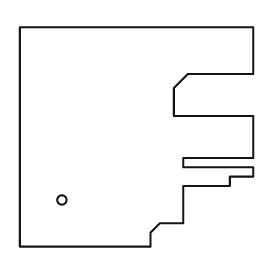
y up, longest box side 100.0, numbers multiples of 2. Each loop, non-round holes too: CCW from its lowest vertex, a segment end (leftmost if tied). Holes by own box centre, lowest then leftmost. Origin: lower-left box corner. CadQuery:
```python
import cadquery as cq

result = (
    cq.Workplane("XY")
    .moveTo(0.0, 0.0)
    .lineTo(56.0, 0.0)
    .lineTo(56.0, 6.0)
    .lineTo(60.0, 10.0)
    .lineTo(70.0, 10.0)
    .lineTo(70.0, 26.0)
    .lineTo(90.0, 26.0)
    .lineTo(90.0, 30.0)
    .lineTo(100.0, 30.0)
    .lineTo(100.0, 34.0)
    .lineTo(70.0, 34.0)
    .lineTo(70.0, 38.0)
    .lineTo(100.0, 38.0)
    .lineTo(100.0, 56.0)
    .lineTo(66.0, 56.0)
    .lineTo(66.0, 68.0)
    .lineTo(72.0, 74.0)
    .lineTo(100.0, 74.0)
    .lineTo(100.0, 94.0)
    .lineTo(0.0, 94.0)
    .close()
    .moveTo(18.0, 20.0)
    .circle(2.0)
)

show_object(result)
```